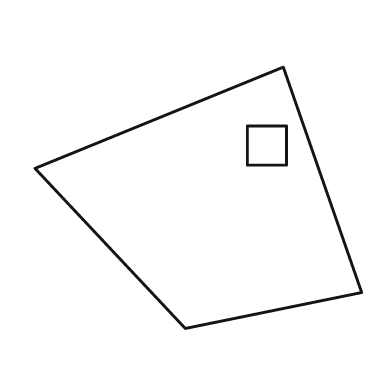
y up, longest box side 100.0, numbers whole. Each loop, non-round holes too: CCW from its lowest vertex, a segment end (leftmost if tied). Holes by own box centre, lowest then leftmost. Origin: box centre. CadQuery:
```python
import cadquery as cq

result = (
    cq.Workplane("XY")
    .moveTo(-4.0, -40.0)
    .lineTo(50.0, -29.0)
    .lineTo(26.0, 40.0)
    .lineTo(-50.0, 9.0)
    .close()
    .moveTo(15.0, 10.0)
    .lineTo(27.0, 10.0)
    .lineTo(27.0, 22.0)
    .lineTo(15.0, 22.0)
    .close()
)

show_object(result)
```